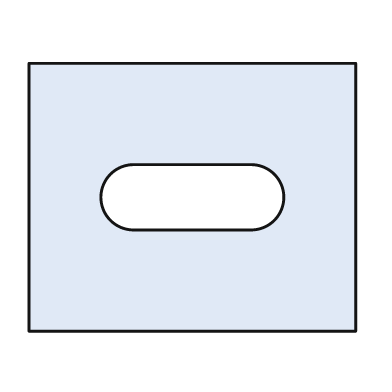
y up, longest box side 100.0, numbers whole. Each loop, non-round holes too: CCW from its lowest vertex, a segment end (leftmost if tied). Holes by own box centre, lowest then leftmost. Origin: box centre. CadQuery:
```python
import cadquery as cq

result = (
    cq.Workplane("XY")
    .moveTo(-50.0, -41.0)
    .lineTo(50.0, -41.0)
    .lineTo(50.0, 41.0)
    .lineTo(-50.0, 41.0)
    .close()
    .moveTo(-18.0, -10.0)
    .lineTo(18.0, -10.0)
    .threePointArc((28.0, 0.0), (18.0, 10.0))
    .lineTo(-18.0, 10.0)
    .threePointArc((-28.0, 0.0), (-18.0, -10.0))
    .close()
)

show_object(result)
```